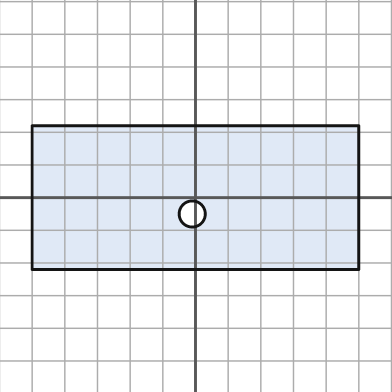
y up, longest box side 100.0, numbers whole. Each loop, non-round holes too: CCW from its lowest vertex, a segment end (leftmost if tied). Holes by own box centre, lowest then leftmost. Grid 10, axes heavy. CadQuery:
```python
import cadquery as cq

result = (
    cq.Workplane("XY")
    .moveTo(-50.0, -22.0)
    .lineTo(50.0, -22.0)
    .lineTo(50.0, 22.0)
    .lineTo(-50.0, 22.0)
    .close()
    .moveTo(-1.0, -5.0)
    .circle(4.0)
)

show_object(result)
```